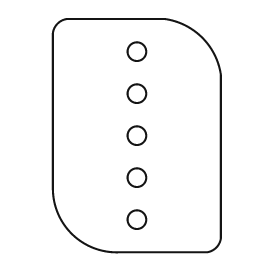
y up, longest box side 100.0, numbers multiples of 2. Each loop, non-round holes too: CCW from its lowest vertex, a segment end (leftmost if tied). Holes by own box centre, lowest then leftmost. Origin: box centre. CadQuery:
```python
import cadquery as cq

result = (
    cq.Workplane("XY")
    .moveTo(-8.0, -50.0)
    .lineTo(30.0, -50.0)
    .threePointArc((34.0, -48.0), (36.0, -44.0))
    .lineTo(36.0, 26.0)
    .threePointArc((28.0, 42.0), (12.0, 50.0))
    .lineTo(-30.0, 50.0)
    .threePointArc((-34.0, 48.0), (-36.0, 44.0))
    .lineTo(-36.0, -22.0)
    .threePointArc((-28.0, -42.0), (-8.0, -50.0))
    .close()
    .moveTo(0.0, -36.0)
    .circle(4.0)
    .moveTo(0.0, -18.0)
    .circle(4.0)
    .moveTo(0.0, 0.0)
    .circle(4.0)
    .moveTo(0.0, 18.0)
    .circle(4.0)
    .moveTo(0.0, 36.0)
    .circle(4.0)
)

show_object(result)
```